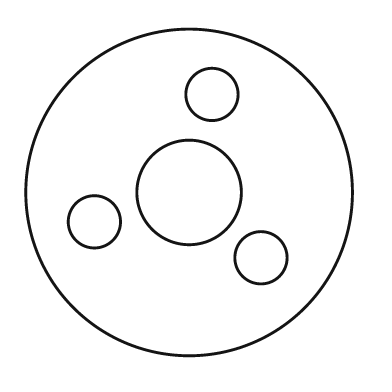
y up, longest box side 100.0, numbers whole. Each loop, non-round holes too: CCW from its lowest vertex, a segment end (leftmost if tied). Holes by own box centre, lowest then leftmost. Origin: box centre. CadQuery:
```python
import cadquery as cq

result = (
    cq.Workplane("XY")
    .moveTo(0.0, 0.0)
    .circle(50.0)
    .moveTo(22.0, -20.0)
    .circle(8.0)
    .moveTo(-29.0, -9.0)
    .circle(8.0)
    .moveTo(0.0, 0.0)
    .circle(16.0)
    .moveTo(7.0, 30.0)
    .circle(8.0)
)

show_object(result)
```